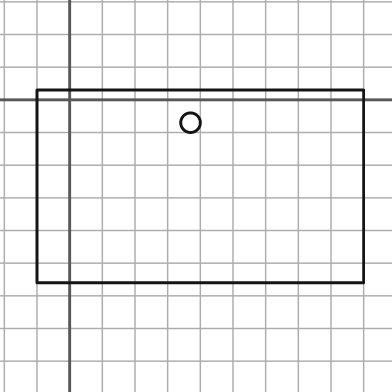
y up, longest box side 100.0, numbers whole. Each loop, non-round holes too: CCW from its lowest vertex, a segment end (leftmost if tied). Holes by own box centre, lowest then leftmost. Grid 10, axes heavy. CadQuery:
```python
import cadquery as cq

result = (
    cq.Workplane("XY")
    .moveTo(-10.0, -56.0)
    .lineTo(90.0, -56.0)
    .lineTo(90.0, 3.0)
    .lineTo(-10.0, 3.0)
    .close()
    .moveTo(37.0, -7.0)
    .circle(3.0)
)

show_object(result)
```